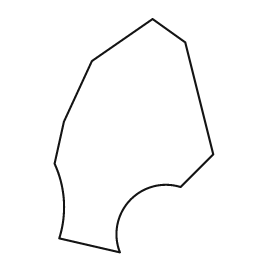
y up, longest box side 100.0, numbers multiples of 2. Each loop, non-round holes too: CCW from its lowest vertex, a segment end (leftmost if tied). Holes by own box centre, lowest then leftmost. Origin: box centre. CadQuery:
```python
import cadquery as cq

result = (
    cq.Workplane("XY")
    .moveTo(-6.0, -50.0)
    .threePointArc((-2.0, -28.0), (20.0, -22.0))
    .lineTo(34.0, -8.0)
    .lineTo(22.0, 40.0)
    .lineTo(8.0, 50.0)
    .lineTo(-18.0, 32.0)
    .lineTo(-30.0, 6.0)
    .lineTo(-34.0, -12.0)
    .threePointArc((-30.0, -28.0), (-32.0, -44.0))
    .close()
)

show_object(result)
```